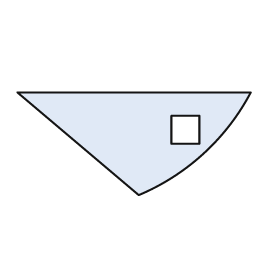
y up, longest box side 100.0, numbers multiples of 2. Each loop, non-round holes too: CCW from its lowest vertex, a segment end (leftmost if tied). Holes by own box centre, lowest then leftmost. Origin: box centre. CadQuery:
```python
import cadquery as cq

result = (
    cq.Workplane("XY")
    .moveTo(2.0, -22.0)
    .threePointArc((30.0, -4.0), (50.0, 22.0))
    .lineTo(-50.0, 22.0)
    .close()
    .moveTo(16.0, 0.0)
    .lineTo(28.0, 0.0)
    .lineTo(28.0, 12.0)
    .lineTo(16.0, 12.0)
    .close()
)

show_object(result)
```